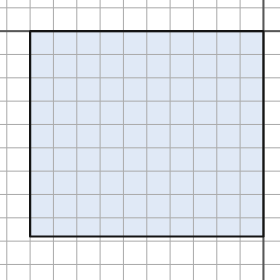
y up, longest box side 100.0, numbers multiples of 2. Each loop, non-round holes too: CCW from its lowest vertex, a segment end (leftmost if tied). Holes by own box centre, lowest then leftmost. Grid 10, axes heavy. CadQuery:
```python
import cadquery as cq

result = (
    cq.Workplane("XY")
    .moveTo(-100.0, -88.0)
    .lineTo(0.0, -88.0)
    .lineTo(0.0, 0.0)
    .lineTo(-100.0, 0.0)
    .close()
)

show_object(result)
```